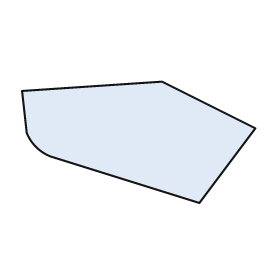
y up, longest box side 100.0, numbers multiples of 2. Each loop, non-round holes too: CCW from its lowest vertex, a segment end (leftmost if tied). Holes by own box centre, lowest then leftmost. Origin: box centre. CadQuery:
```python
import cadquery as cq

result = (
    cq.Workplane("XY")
    .moveTo(26.0, -26.0)
    .lineTo(50.0, 6.0)
    .lineTo(10.0, 26.0)
    .lineTo(-50.0, 22.0)
    .lineTo(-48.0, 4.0)
    .threePointArc((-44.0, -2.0), (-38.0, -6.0))
    .close()
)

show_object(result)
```